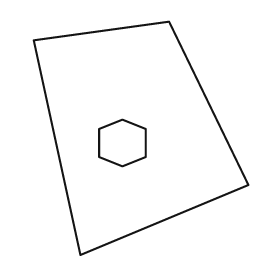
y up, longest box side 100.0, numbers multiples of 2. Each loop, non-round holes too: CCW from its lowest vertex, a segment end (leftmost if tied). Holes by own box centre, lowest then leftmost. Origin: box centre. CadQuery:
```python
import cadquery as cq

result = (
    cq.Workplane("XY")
    .moveTo(-26.0, -50.0)
    .lineTo(46.0, -20.0)
    .lineTo(12.0, 50.0)
    .lineTo(-46.0, 42.0)
    .close()
    .moveTo(-8.0, -12.0)
    .lineTo(2.0, -8.0)
    .lineTo(2.0, 4.0)
    .lineTo(-8.0, 8.0)
    .lineTo(-18.0, 4.0)
    .lineTo(-18.0, -8.0)
    .close()
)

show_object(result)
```